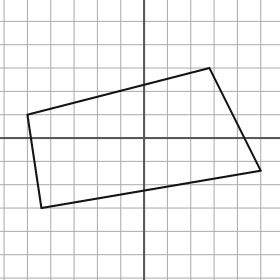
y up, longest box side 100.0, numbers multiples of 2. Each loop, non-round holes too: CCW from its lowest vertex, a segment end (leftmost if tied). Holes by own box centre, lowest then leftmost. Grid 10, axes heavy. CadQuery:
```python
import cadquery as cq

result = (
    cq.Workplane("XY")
    .moveTo(-44.0, -30.0)
    .lineTo(50.0, -14.0)
    .lineTo(28.0, 30.0)
    .lineTo(-50.0, 10.0)
    .close()
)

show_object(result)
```